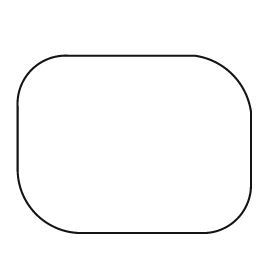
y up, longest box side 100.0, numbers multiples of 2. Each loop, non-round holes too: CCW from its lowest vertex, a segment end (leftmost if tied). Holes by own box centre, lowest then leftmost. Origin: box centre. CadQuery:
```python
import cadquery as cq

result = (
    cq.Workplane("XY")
    .moveTo(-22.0, -38.0)
    .lineTo(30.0, -38.0)
    .threePointArc((44.0, -32.0), (50.0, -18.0))
    .lineTo(50.0, 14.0)
    .threePointArc((42.0, 30.0), (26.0, 38.0))
    .lineTo(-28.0, 38.0)
    .threePointArc((-44.0, 32.0), (-50.0, 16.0))
    .lineTo(-50.0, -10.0)
    .threePointArc((-42.0, -30.0), (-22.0, -38.0))
    .close()
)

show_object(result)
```